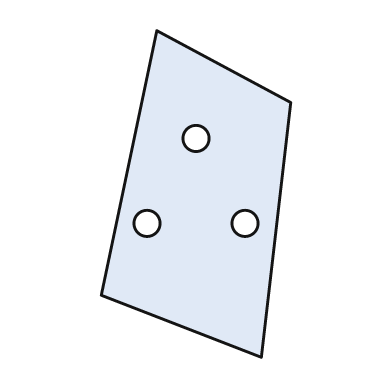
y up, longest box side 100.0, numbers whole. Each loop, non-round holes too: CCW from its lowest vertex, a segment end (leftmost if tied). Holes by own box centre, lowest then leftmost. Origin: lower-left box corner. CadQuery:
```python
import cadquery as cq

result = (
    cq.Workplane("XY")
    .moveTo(49.0, 0.0)
    .lineTo(58.0, 78.0)
    .lineTo(17.0, 100.0)
    .lineTo(0.0, 19.0)
    .close()
    .moveTo(14.0, 41.0)
    .circle(4.0)
    .moveTo(44.0, 41.0)
    .circle(4.0)
    .moveTo(29.0, 67.0)
    .circle(4.0)
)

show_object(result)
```